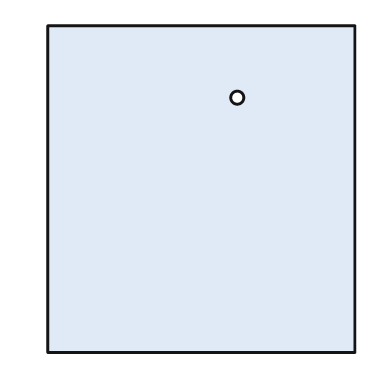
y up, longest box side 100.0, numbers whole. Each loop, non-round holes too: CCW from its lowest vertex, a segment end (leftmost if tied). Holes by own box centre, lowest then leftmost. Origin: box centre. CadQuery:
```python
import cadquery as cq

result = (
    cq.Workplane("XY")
    .moveTo(-47.0, -50.0)
    .lineTo(47.0, -50.0)
    .lineTo(47.0, 50.0)
    .lineTo(-47.0, 50.0)
    .close()
    .moveTo(11.0, 28.0)
    .circle(2.0)
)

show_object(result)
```